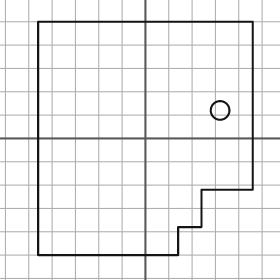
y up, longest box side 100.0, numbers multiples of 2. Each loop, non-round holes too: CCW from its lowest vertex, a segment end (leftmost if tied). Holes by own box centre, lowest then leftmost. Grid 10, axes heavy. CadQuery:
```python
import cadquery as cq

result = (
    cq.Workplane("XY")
    .moveTo(-46.0, -50.0)
    .lineTo(14.0, -50.0)
    .lineTo(14.0, -38.0)
    .lineTo(24.0, -38.0)
    .lineTo(24.0, -22.0)
    .lineTo(46.0, -22.0)
    .lineTo(46.0, 50.0)
    .lineTo(-46.0, 50.0)
    .close()
    .moveTo(32.0, 12.0)
    .circle(4.0)
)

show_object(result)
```